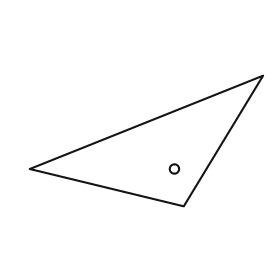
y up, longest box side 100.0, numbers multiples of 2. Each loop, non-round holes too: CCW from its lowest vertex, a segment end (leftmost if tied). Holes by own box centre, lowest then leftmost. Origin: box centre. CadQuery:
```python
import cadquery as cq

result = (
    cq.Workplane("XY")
    .moveTo(16.0, -28.0)
    .lineTo(50.0, 28.0)
    .lineTo(-50.0, -12.0)
    .close()
    .moveTo(12.0, -12.0)
    .circle(2.0)
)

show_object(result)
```